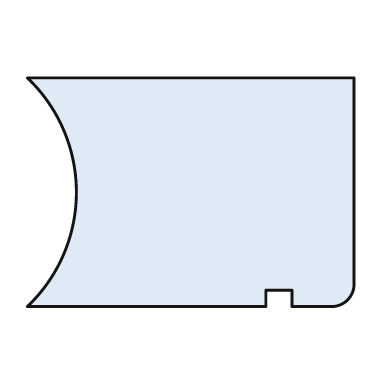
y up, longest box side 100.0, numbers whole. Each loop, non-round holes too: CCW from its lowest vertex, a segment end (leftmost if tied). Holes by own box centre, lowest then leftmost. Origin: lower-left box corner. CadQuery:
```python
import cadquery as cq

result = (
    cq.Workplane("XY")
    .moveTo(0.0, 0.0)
    .lineTo(73.0, 0.0)
    .lineTo(73.0, 5.0)
    .lineTo(81.0, 5.0)
    .lineTo(81.0, 0.0)
    .lineTo(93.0, 0.0)
    .threePointArc((98.0, 2.0), (100.0, 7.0))
    .lineTo(100.0, 70.0)
    .lineTo(0.0, 70.0)
    .threePointArc((15.0, 35.0), (0.0, 0.0))
    .close()
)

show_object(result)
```